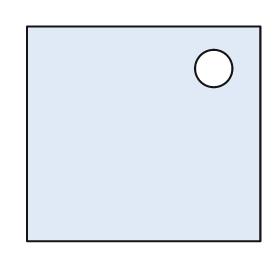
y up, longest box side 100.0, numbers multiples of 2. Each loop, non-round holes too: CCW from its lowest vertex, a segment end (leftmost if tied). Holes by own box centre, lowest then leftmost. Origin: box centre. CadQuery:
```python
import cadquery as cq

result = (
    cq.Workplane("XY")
    .moveTo(-50.0, -46.0)
    .lineTo(50.0, -46.0)
    .lineTo(50.0, 46.0)
    .lineTo(-50.0, 46.0)
    .close()
    .moveTo(30.0, 28.0)
    .circle(8.0)
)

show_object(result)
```